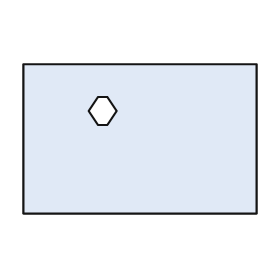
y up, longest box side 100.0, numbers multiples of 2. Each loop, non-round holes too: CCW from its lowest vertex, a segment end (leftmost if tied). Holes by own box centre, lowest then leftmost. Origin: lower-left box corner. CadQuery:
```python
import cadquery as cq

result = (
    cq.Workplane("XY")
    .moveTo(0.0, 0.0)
    .lineTo(100.0, 0.0)
    .lineTo(100.0, 64.0)
    .lineTo(0.0, 64.0)
    .close()
    .moveTo(32.0, 38.0)
    .lineTo(36.0, 38.0)
    .lineTo(40.0, 44.0)
    .lineTo(36.0, 50.0)
    .lineTo(32.0, 50.0)
    .lineTo(28.0, 44.0)
    .close()
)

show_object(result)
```